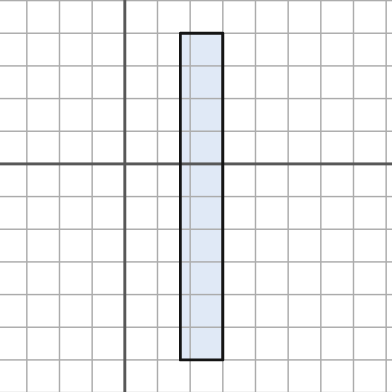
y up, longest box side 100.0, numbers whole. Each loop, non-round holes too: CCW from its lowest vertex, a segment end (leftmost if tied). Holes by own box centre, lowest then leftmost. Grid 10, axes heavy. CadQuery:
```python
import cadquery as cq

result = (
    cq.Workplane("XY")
    .moveTo(17.0, -60.0)
    .lineTo(30.0, -60.0)
    .lineTo(30.0, 40.0)
    .lineTo(17.0, 40.0)
    .close()
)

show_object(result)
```